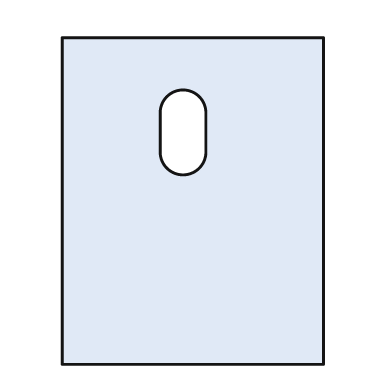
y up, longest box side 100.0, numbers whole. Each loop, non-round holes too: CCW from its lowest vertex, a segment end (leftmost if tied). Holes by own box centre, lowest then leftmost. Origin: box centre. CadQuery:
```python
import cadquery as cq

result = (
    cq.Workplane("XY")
    .moveTo(-40.0, -50.0)
    .lineTo(40.0, -50.0)
    .lineTo(40.0, 50.0)
    .lineTo(-40.0, 50.0)
    .close()
    .moveTo(-10.0, 15.0)
    .threePointArc((-3.0, 8.0), (4.0, 15.0))
    .lineTo(4.0, 27.0)
    .threePointArc((-3.0, 34.0), (-10.0, 27.0))
    .close()
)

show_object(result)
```